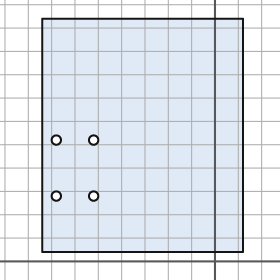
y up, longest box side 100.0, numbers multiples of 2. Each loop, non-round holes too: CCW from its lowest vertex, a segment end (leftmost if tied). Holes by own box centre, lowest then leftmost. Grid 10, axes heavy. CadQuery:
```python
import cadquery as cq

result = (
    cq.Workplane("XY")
    .moveTo(-74.0, 4.0)
    .lineTo(12.0, 4.0)
    .lineTo(12.0, 104.0)
    .lineTo(-74.0, 104.0)
    .close()
    .moveTo(-68.0, 28.0)
    .circle(2.0)
    .moveTo(-52.0, 28.0)
    .circle(2.0)
    .moveTo(-68.0, 52.0)
    .circle(2.0)
    .moveTo(-52.0, 52.0)
    .circle(2.0)
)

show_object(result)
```